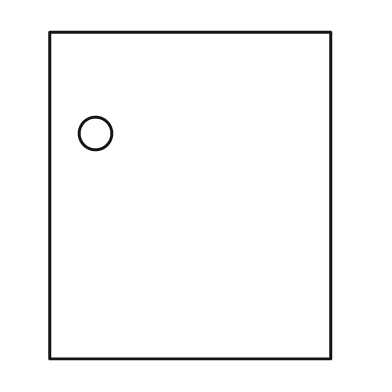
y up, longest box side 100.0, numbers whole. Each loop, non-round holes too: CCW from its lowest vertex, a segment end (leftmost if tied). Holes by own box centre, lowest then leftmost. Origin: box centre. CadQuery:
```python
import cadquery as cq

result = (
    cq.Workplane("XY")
    .moveTo(-43.0, -50.0)
    .lineTo(43.0, -50.0)
    .lineTo(43.0, 50.0)
    .lineTo(-43.0, 50.0)
    .close()
    .moveTo(-29.0, 19.0)
    .circle(5.0)
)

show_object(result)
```